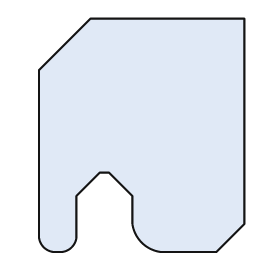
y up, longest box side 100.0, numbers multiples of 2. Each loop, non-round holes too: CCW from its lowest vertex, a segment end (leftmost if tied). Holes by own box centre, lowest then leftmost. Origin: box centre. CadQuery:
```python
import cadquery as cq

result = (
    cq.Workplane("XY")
    .moveTo(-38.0, -50.0)
    .lineTo(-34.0, -50.0)
    .threePointArc((-30.0, -48.0), (-28.0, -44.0))
    .lineTo(-28.0, -26.0)
    .lineTo(-18.0, -16.0)
    .lineTo(-14.0, -16.0)
    .lineTo(-4.0, -26.0)
    .lineTo(-4.0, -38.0)
    .threePointArc((0.0, -46.0), (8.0, -50.0))
    .lineTo(32.0, -50.0)
    .lineTo(44.0, -38.0)
    .lineTo(44.0, 50.0)
    .lineTo(-22.0, 50.0)
    .lineTo(-44.0, 28.0)
    .lineTo(-44.0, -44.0)
    .threePointArc((-42.0, -48.0), (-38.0, -50.0))
    .close()
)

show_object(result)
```